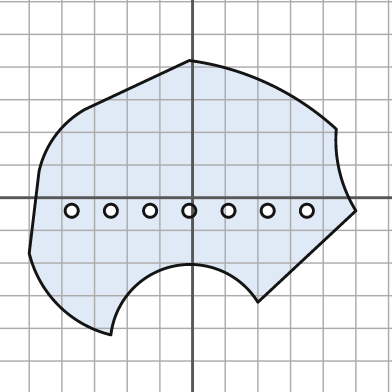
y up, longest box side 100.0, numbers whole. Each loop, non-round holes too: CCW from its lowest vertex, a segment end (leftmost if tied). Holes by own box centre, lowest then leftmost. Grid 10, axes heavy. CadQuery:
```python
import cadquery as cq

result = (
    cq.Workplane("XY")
    .moveTo(-25.0, -42.0)
    .threePointArc((-6.0, -21.0), (20.0, -32.0))
    .lineTo(50.0, -4.0)
    .threePointArc((45.0, 8.0), (44.0, 21.0))
    .threePointArc((23.0, 35.0), (-1.0, 42.0))
    .lineTo(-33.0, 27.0)
    .threePointArc((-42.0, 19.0), (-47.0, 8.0))
    .lineTo(-50.0, -17.0)
    .threePointArc((-41.0, -33.0), (-25.0, -42.0))
    .close()
    .moveTo(-37.0, -4.0)
    .circle(2.0)
    .moveTo(-25.0, -4.0)
    .circle(2.0)
    .moveTo(-13.0, -4.0)
    .circle(2.0)
    .moveTo(-1.0, -4.0)
    .circle(2.0)
    .moveTo(11.0, -4.0)
    .circle(2.0)
    .moveTo(23.0, -4.0)
    .circle(2.0)
    .moveTo(35.0, -4.0)
    .circle(2.0)
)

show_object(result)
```